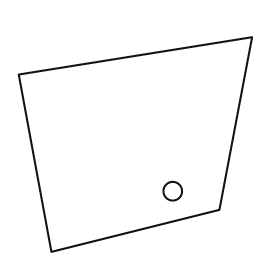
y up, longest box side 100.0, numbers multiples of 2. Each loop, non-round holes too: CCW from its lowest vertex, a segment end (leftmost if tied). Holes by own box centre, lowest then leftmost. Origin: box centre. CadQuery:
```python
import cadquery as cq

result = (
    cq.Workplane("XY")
    .moveTo(-36.0, -46.0)
    .lineTo(36.0, -28.0)
    .lineTo(50.0, 46.0)
    .lineTo(-50.0, 30.0)
    .close()
    .moveTo(16.0, -20.0)
    .circle(4.0)
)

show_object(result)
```